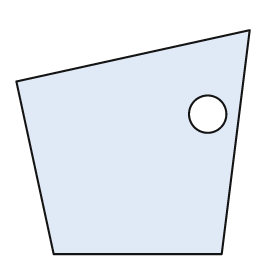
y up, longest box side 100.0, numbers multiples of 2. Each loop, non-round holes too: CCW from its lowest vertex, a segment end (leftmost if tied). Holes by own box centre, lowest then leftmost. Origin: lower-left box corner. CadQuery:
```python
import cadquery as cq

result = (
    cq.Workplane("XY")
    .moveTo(16.0, 0.0)
    .lineTo(88.0, 0.0)
    .lineTo(100.0, 96.0)
    .lineTo(0.0, 74.0)
    .close()
    .moveTo(82.0, 60.0)
    .circle(8.0)
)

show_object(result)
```